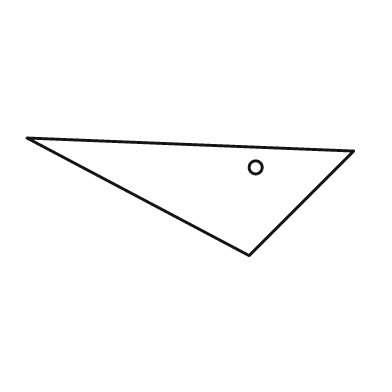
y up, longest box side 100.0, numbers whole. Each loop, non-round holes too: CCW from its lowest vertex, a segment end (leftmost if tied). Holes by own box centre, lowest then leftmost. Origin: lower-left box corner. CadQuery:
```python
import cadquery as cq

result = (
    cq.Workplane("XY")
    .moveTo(68.0, 0.0)
    .lineTo(100.0, 32.0)
    .lineTo(0.0, 36.0)
    .close()
    .moveTo(70.0, 27.0)
    .circle(2.0)
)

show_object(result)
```